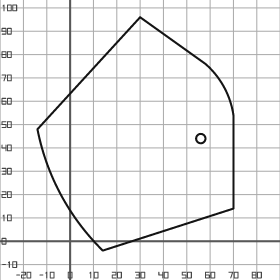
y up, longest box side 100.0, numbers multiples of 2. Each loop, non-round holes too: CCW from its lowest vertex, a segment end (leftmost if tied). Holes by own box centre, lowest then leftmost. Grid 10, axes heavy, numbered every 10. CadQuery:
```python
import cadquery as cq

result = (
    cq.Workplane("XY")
    .moveTo(14.0, -4.0)
    .lineTo(70.0, 14.0)
    .lineTo(70.0, 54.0)
    .threePointArc((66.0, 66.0), (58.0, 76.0))
    .lineTo(30.0, 96.0)
    .lineTo(-14.0, 48.0)
    .threePointArc((-4.0, 20.0), (14.0, -4.0))
    .close()
    .moveTo(56.0, 44.0)
    .circle(2.0)
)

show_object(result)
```